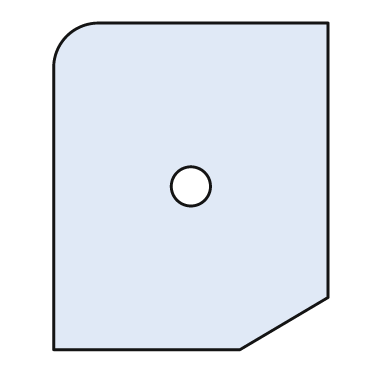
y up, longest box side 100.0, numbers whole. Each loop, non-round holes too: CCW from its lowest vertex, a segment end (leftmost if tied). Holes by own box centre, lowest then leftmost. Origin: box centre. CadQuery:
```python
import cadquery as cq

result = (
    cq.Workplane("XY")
    .moveTo(-42.0, -50.0)
    .lineTo(15.0, -50.0)
    .lineTo(42.0, -34.0)
    .lineTo(42.0, 50.0)
    .lineTo(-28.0, 50.0)
    .threePointArc((-38.0, 46.0), (-42.0, 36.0))
    .close()
    .moveTo(0.0, 0.0)
    .circle(6.0)
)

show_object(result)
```